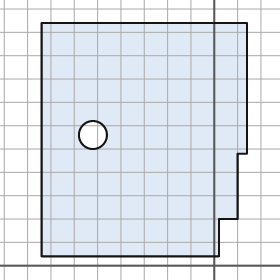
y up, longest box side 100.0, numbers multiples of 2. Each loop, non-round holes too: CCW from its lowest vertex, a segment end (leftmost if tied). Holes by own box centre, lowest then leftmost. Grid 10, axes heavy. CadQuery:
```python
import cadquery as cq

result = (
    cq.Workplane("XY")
    .moveTo(-74.0, 4.0)
    .lineTo(2.0, 4.0)
    .lineTo(2.0, 20.0)
    .lineTo(10.0, 20.0)
    .lineTo(10.0, 48.0)
    .lineTo(14.0, 48.0)
    .lineTo(14.0, 104.0)
    .lineTo(-74.0, 104.0)
    .close()
    .moveTo(-52.0, 56.0)
    .circle(6.0)
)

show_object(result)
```